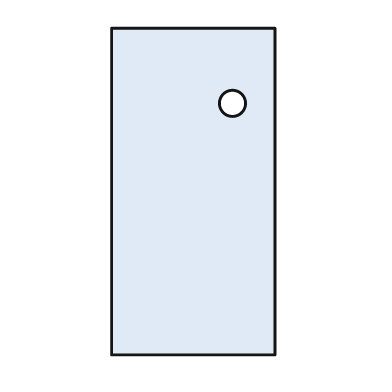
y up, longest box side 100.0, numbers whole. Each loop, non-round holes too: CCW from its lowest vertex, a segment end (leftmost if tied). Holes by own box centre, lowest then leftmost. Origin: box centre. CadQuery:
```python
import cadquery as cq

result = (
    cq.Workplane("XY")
    .moveTo(-25.0, -50.0)
    .lineTo(25.0, -50.0)
    .lineTo(25.0, 50.0)
    .lineTo(-25.0, 50.0)
    .close()
    .moveTo(12.0, 27.0)
    .circle(4.0)
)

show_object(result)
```